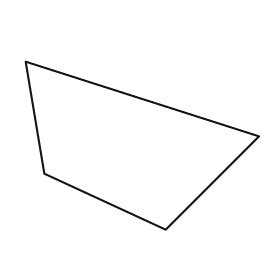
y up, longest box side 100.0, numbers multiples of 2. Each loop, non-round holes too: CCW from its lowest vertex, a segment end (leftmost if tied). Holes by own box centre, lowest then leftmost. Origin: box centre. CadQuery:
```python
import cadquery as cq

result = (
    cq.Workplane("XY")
    .moveTo(10.0, -36.0)
    .lineTo(50.0, 4.0)
    .lineTo(-50.0, 36.0)
    .lineTo(-42.0, -12.0)
    .close()
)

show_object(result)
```